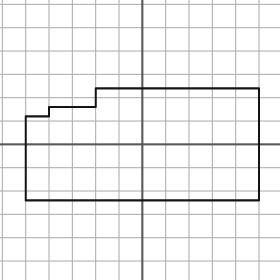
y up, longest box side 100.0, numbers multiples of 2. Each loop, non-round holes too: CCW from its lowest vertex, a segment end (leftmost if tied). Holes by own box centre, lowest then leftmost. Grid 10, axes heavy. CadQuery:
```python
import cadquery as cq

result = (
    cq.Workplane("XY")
    .moveTo(-50.0, -24.0)
    .lineTo(50.0, -24.0)
    .lineTo(50.0, 24.0)
    .lineTo(-20.0, 24.0)
    .lineTo(-20.0, 16.0)
    .lineTo(-40.0, 16.0)
    .lineTo(-40.0, 12.0)
    .lineTo(-50.0, 12.0)
    .close()
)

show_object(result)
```